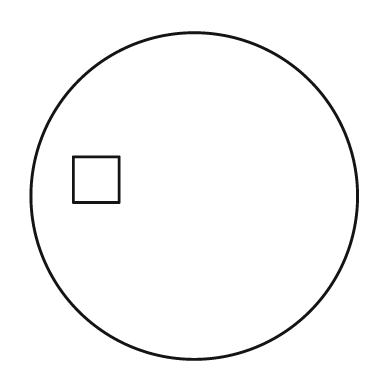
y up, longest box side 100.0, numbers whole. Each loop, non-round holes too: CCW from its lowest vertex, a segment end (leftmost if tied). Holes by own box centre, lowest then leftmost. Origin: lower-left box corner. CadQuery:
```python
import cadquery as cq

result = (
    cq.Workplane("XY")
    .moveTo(50.0, 50.0)
    .circle(50.0)
    .moveTo(13.0, 48.0)
    .lineTo(27.0, 48.0)
    .lineTo(27.0, 62.0)
    .lineTo(13.0, 62.0)
    .close()
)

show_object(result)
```